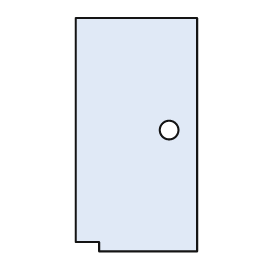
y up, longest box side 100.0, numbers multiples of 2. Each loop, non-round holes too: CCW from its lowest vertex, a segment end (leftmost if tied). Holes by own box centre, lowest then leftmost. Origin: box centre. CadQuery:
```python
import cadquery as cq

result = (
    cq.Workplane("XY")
    .moveTo(-16.0, -50.0)
    .lineTo(26.0, -50.0)
    .lineTo(26.0, 50.0)
    .lineTo(-26.0, 50.0)
    .lineTo(-26.0, -46.0)
    .lineTo(-16.0, -46.0)
    .close()
    .moveTo(14.0, 2.0)
    .circle(4.0)
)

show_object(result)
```